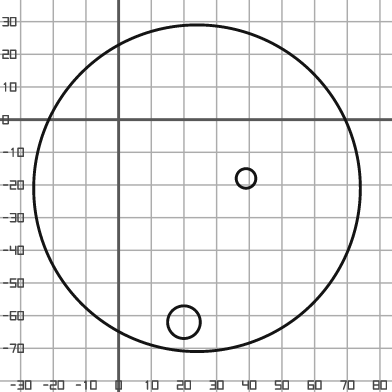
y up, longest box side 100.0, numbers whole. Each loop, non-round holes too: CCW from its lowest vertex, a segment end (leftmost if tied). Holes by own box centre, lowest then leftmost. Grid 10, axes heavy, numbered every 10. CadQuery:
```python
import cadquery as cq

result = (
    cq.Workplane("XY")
    .moveTo(24.0, -21.0)
    .circle(50.0)
    .moveTo(20.0, -62.0)
    .circle(5.0)
    .moveTo(39.0, -18.0)
    .circle(3.0)
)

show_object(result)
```